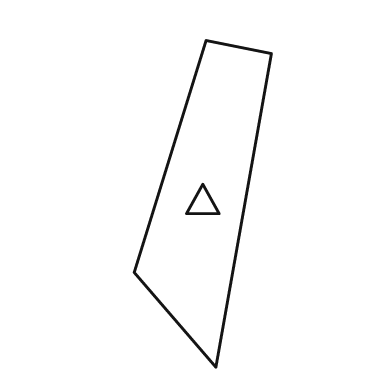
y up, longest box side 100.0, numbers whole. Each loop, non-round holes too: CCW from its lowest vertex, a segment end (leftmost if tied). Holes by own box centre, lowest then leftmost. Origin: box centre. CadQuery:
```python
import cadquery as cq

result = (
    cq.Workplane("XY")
    .moveTo(4.0, -50.0)
    .lineTo(21.0, 46.0)
    .lineTo(1.0, 50.0)
    .lineTo(-21.0, -21.0)
    .close()
    .moveTo(-5.0, -3.0)
    .lineTo(5.0, -3.0)
    .lineTo(0.0, 6.0)
    .close()
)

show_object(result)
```